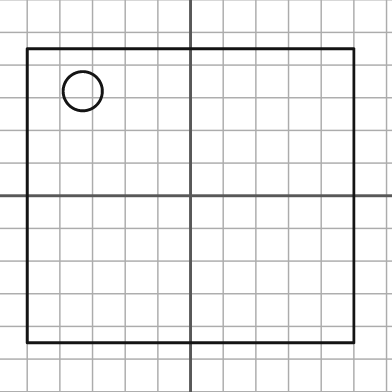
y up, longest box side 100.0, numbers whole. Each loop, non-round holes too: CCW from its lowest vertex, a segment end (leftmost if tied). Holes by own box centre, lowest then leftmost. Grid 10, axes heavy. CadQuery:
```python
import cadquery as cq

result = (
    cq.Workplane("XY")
    .moveTo(-50.0, -45.0)
    .lineTo(50.0, -45.0)
    .lineTo(50.0, 45.0)
    .lineTo(-50.0, 45.0)
    .close()
    .moveTo(-33.0, 32.0)
    .circle(6.0)
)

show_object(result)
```